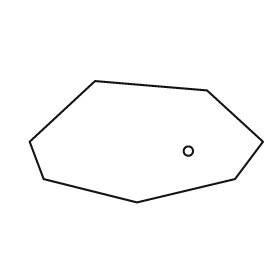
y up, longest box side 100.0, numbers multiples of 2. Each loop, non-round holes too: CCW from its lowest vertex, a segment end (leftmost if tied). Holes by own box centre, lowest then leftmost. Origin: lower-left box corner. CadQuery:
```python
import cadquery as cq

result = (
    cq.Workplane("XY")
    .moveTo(46.0, 0.0)
    .lineTo(88.0, 10.0)
    .lineTo(100.0, 26.0)
    .lineTo(76.0, 48.0)
    .lineTo(28.0, 52.0)
    .lineTo(0.0, 26.0)
    .lineTo(6.0, 10.0)
    .close()
    .moveTo(68.0, 22.0)
    .circle(2.0)
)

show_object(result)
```